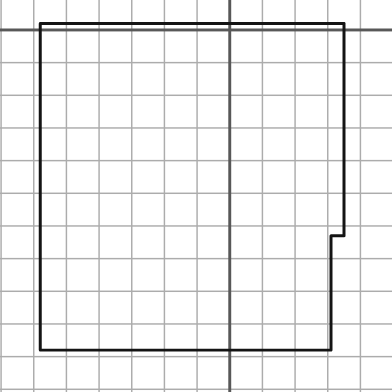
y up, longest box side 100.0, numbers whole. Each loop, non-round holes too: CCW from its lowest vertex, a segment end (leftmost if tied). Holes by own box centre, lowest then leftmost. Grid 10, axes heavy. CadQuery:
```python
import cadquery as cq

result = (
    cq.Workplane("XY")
    .moveTo(-58.0, -98.0)
    .lineTo(31.0, -98.0)
    .lineTo(31.0, -63.0)
    .lineTo(35.0, -63.0)
    .lineTo(35.0, 2.0)
    .lineTo(-58.0, 2.0)
    .close()
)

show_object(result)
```